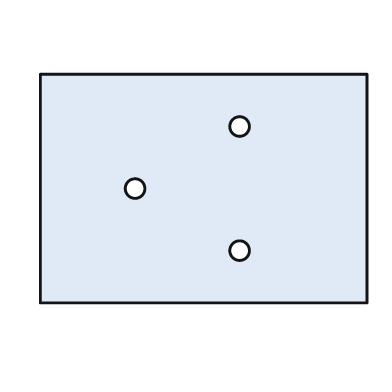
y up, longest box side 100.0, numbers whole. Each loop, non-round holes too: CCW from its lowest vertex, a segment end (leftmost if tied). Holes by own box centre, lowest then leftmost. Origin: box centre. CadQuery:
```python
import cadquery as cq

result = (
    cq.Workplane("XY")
    .moveTo(-50.0, -35.0)
    .lineTo(50.0, -35.0)
    .lineTo(50.0, 35.0)
    .lineTo(-50.0, 35.0)
    .close()
    .moveTo(11.0, -19.0)
    .circle(3.0)
    .moveTo(-21.0, 0.0)
    .circle(3.0)
    .moveTo(11.0, 19.0)
    .circle(3.0)
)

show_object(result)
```